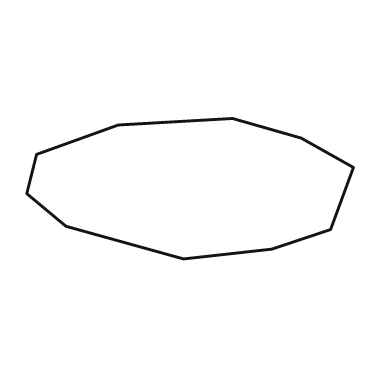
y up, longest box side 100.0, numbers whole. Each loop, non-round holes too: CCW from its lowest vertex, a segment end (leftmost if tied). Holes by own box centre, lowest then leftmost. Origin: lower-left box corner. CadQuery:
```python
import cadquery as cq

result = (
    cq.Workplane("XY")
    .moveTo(48.0, 0.0)
    .lineTo(75.0, 3.0)
    .lineTo(93.0, 9.0)
    .lineTo(100.0, 28.0)
    .lineTo(84.0, 37.0)
    .lineTo(63.0, 43.0)
    .lineTo(28.0, 41.0)
    .lineTo(3.0, 32.0)
    .lineTo(0.0, 20.0)
    .lineTo(12.0, 10.0)
    .close()
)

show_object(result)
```